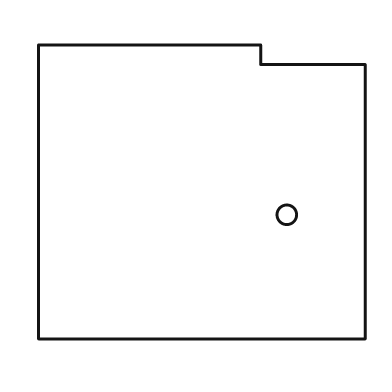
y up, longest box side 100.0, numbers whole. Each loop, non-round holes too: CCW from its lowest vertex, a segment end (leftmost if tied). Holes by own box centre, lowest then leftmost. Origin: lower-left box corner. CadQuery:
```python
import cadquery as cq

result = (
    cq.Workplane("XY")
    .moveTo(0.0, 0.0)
    .lineTo(100.0, 0.0)
    .lineTo(100.0, 84.0)
    .lineTo(68.0, 84.0)
    .lineTo(68.0, 90.0)
    .lineTo(0.0, 90.0)
    .close()
    .moveTo(76.0, 38.0)
    .circle(3.0)
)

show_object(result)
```